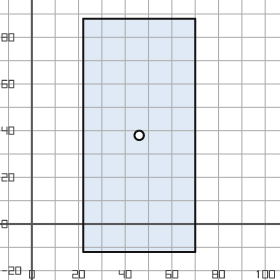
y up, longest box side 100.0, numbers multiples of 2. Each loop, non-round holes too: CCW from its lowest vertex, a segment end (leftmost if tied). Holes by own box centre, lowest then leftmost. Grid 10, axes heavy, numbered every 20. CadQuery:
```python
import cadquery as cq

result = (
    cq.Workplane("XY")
    .moveTo(22.0, -12.0)
    .lineTo(70.0, -12.0)
    .lineTo(70.0, 88.0)
    .lineTo(22.0, 88.0)
    .close()
    .moveTo(46.0, 38.0)
    .circle(2.0)
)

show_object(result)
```